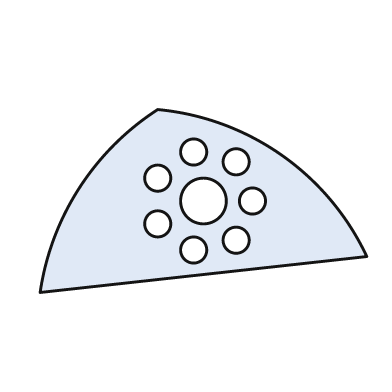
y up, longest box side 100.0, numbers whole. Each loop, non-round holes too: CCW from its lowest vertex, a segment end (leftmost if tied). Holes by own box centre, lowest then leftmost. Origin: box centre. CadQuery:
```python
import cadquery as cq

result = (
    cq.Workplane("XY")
    .moveTo(-50.0, -28.0)
    .lineTo(50.0, -17.0)
    .threePointArc((24.0, 14.0), (-14.0, 28.0))
    .threePointArc((-38.0, 4.0), (-50.0, -28.0))
    .close()
    .moveTo(-3.0, -15.0)
    .circle(4.0)
    .moveTo(10.0, -12.0)
    .circle(4.0)
    .moveTo(-14.0, -7.0)
    .circle(4.0)
    .moveTo(0.0, 0.0)
    .circle(7.0)
    .moveTo(15.0, 0.0)
    .circle(4.0)
    .moveTo(-14.0, 7.0)
    .circle(4.0)
    .moveTo(10.0, 12.0)
    .circle(4.0)
    .moveTo(-3.0, 15.0)
    .circle(4.0)
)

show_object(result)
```